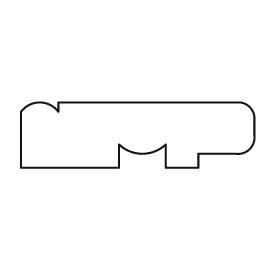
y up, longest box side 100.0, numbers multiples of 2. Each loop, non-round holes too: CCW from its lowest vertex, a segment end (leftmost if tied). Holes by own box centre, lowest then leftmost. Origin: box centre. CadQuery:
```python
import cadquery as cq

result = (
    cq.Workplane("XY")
    .moveTo(-50.0, -14.0)
    .lineTo(-8.0, -14.0)
    .lineTo(-8.0, -4.0)
    .threePointArc((2.0, -8.0), (12.0, -4.0))
    .lineTo(12.0, -14.0)
    .lineTo(26.0, -14.0)
    .lineTo(26.0, -8.0)
    .lineTo(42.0, -8.0)
    .threePointArc((48.0, -6.0), (50.0, 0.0))
    .lineTo(50.0, 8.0)
    .threePointArc((48.0, 12.0), (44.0, 14.0))
    .lineTo(-34.0, 14.0)
    .lineTo(-34.0, 10.0)
    .threePointArc((-42.0, 14.0), (-50.0, 10.0))
    .close()
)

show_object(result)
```